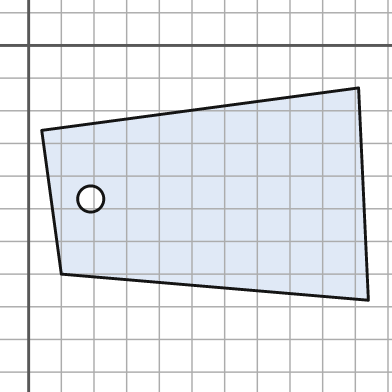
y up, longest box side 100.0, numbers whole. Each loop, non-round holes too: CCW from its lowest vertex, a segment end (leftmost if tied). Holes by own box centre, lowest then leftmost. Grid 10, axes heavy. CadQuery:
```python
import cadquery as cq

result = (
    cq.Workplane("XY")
    .moveTo(104.0, -78.0)
    .lineTo(101.0, -13.0)
    .lineTo(4.0, -26.0)
    .lineTo(10.0, -70.0)
    .close()
    .moveTo(19.0, -47.0)
    .circle(4.0)
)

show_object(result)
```